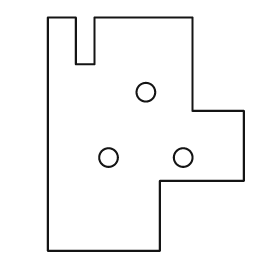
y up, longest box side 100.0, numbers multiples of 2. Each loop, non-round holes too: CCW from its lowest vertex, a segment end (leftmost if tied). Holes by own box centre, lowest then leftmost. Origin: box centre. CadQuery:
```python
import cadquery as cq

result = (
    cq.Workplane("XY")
    .moveTo(-42.0, -50.0)
    .lineTo(6.0, -50.0)
    .lineTo(6.0, -20.0)
    .lineTo(42.0, -20.0)
    .lineTo(42.0, 10.0)
    .lineTo(20.0, 10.0)
    .lineTo(20.0, 50.0)
    .lineTo(-22.0, 50.0)
    .lineTo(-22.0, 30.0)
    .lineTo(-30.0, 30.0)
    .lineTo(-30.0, 50.0)
    .lineTo(-42.0, 50.0)
    .close()
    .moveTo(-16.0, -10.0)
    .circle(4.0)
    .moveTo(16.0, -10.0)
    .circle(4.0)
    .moveTo(0.0, 18.0)
    .circle(4.0)
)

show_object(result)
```